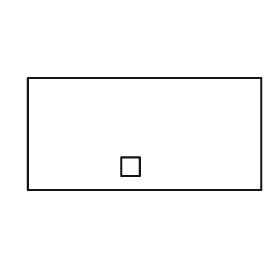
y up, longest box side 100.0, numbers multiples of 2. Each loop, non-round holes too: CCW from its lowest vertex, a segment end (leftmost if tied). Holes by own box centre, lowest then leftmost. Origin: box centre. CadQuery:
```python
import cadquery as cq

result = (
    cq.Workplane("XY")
    .moveTo(-50.0, -24.0)
    .lineTo(50.0, -24.0)
    .lineTo(50.0, 24.0)
    .lineTo(-50.0, 24.0)
    .close()
    .moveTo(-10.0, -18.0)
    .lineTo(-2.0, -18.0)
    .lineTo(-2.0, -10.0)
    .lineTo(-10.0, -10.0)
    .close()
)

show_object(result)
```